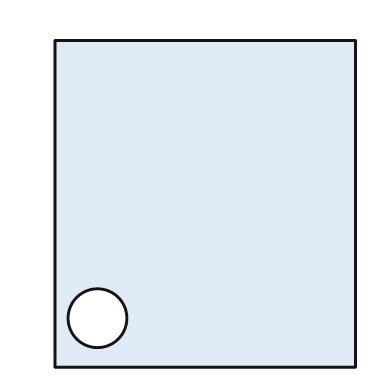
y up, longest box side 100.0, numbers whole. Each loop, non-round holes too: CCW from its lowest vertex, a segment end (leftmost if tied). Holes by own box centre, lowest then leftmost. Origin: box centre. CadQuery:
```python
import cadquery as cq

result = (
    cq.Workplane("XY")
    .moveTo(-46.0, -50.0)
    .lineTo(46.0, -50.0)
    .lineTo(46.0, 50.0)
    .lineTo(-46.0, 50.0)
    .close()
    .moveTo(-33.0, -35.0)
    .circle(9.0)
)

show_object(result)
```